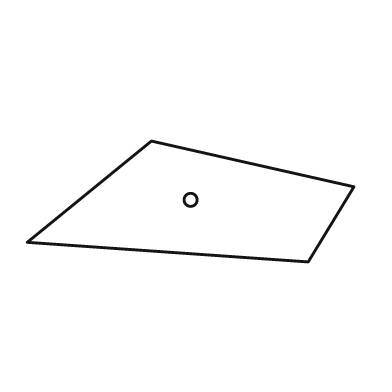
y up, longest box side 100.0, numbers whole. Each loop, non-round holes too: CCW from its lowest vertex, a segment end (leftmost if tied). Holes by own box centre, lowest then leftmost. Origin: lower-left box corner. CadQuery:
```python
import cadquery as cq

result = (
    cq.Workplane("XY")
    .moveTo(86.0, 0.0)
    .lineTo(100.0, 23.0)
    .lineTo(38.0, 37.0)
    .lineTo(0.0, 6.0)
    .close()
    .moveTo(50.0, 19.0)
    .circle(2.0)
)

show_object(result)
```